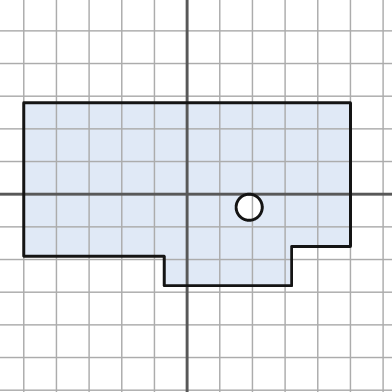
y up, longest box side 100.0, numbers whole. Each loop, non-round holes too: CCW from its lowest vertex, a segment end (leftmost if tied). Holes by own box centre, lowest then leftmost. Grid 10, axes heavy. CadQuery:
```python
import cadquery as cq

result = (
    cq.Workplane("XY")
    .moveTo(-7.0, -28.0)
    .lineTo(32.0, -28.0)
    .lineTo(32.0, -16.0)
    .lineTo(50.0, -16.0)
    .lineTo(50.0, 28.0)
    .lineTo(-50.0, 28.0)
    .lineTo(-50.0, -19.0)
    .lineTo(-7.0, -19.0)
    .close()
    .moveTo(19.0, -4.0)
    .circle(4.0)
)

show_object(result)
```